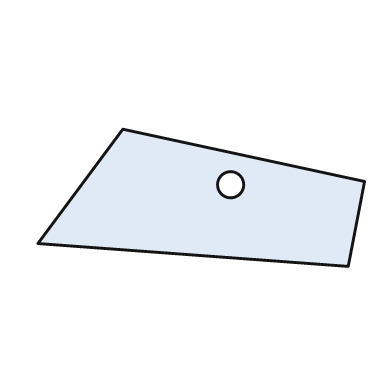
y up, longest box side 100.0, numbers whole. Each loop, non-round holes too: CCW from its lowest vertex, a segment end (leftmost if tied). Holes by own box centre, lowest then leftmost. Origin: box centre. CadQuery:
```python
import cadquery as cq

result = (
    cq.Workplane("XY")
    .moveTo(45.0, -21.0)
    .lineTo(50.0, 5.0)
    .lineTo(-24.0, 21.0)
    .lineTo(-50.0, -14.0)
    .close()
    .moveTo(9.0, 4.0)
    .circle(4.0)
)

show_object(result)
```